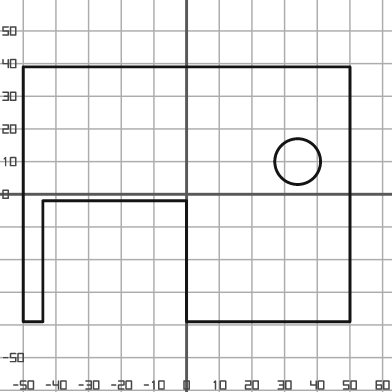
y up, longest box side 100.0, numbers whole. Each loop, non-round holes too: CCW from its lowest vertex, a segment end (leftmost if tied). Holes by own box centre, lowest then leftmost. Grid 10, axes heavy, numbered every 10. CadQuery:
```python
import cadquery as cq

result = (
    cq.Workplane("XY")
    .moveTo(-50.0, -39.0)
    .lineTo(-44.0, -39.0)
    .lineTo(-44.0, -2.0)
    .lineTo(0.0, -2.0)
    .lineTo(0.0, -39.0)
    .lineTo(50.0, -39.0)
    .lineTo(50.0, 39.0)
    .lineTo(-50.0, 39.0)
    .close()
    .moveTo(34.0, 10.0)
    .circle(7.0)
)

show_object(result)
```